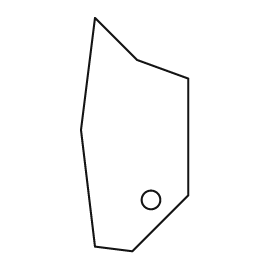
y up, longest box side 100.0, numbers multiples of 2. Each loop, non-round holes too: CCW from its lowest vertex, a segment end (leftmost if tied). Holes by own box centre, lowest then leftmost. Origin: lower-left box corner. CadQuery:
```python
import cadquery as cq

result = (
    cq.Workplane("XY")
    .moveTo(22.0, 0.0)
    .lineTo(46.0, 24.0)
    .lineTo(46.0, 74.0)
    .lineTo(24.0, 82.0)
    .lineTo(6.0, 100.0)
    .lineTo(0.0, 52.0)
    .lineTo(6.0, 2.0)
    .close()
    .moveTo(30.0, 22.0)
    .circle(4.0)
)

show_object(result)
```